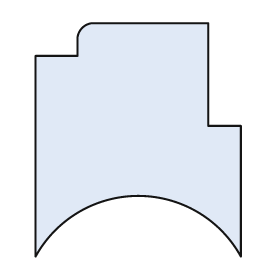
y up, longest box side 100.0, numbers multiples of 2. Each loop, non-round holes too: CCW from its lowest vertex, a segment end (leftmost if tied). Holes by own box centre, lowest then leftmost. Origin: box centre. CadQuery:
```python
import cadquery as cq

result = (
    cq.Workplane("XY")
    .moveTo(-44.0, -50.0)
    .threePointArc((0.0, -24.0), (44.0, -50.0))
    .lineTo(44.0, 6.0)
    .lineTo(30.0, 6.0)
    .lineTo(30.0, 50.0)
    .lineTo(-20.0, 50.0)
    .threePointArc((-24.0, 48.0), (-26.0, 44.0))
    .lineTo(-26.0, 36.0)
    .lineTo(-44.0, 36.0)
    .close()
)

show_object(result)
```